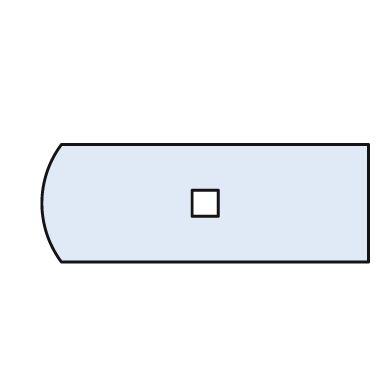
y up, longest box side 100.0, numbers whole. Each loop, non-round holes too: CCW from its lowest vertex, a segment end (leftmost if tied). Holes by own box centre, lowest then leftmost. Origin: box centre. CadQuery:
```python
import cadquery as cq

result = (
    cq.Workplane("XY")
    .moveTo(-44.0, -18.0)
    .lineTo(50.0, -18.0)
    .lineTo(50.0, 18.0)
    .lineTo(-44.0, 18.0)
    .threePointArc((-50.0, 0.0), (-44.0, -18.0))
    .close()
    .moveTo(-4.0, -4.0)
    .lineTo(4.0, -4.0)
    .lineTo(4.0, 4.0)
    .lineTo(-4.0, 4.0)
    .close()
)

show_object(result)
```